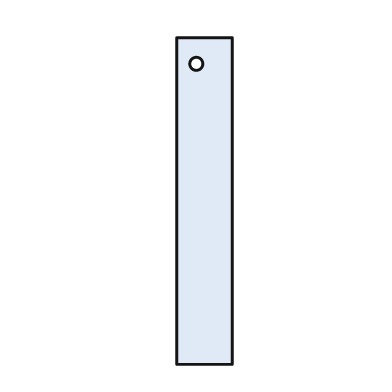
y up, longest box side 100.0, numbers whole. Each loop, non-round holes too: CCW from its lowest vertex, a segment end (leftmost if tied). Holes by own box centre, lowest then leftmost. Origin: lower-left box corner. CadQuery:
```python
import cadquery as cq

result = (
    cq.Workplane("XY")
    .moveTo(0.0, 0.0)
    .lineTo(17.0, 0.0)
    .lineTo(17.0, 100.0)
    .lineTo(0.0, 100.0)
    .close()
    .moveTo(6.0, 92.0)
    .circle(2.0)
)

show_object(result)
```